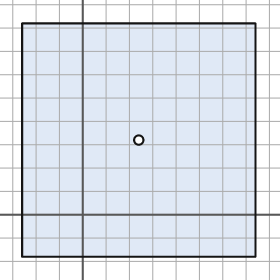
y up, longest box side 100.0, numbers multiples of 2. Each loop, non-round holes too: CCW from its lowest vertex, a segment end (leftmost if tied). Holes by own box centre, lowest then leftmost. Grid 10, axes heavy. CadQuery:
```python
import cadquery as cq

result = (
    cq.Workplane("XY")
    .moveTo(-26.0, -18.0)
    .lineTo(74.0, -18.0)
    .lineTo(74.0, 82.0)
    .lineTo(-26.0, 82.0)
    .close()
    .moveTo(24.0, 32.0)
    .circle(2.0)
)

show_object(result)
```